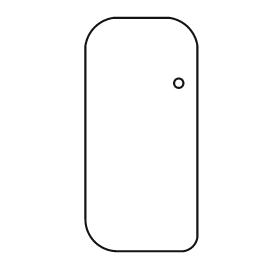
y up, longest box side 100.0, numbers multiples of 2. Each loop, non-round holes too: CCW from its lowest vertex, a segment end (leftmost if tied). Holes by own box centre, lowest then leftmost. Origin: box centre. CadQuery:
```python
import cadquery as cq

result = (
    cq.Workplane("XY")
    .moveTo(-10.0, -50.0)
    .lineTo(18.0, -50.0)
    .threePointArc((22.0, -48.0), (24.0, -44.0))
    .lineTo(24.0, 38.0)
    .threePointArc((20.0, 46.0), (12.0, 50.0))
    .lineTo(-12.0, 50.0)
    .threePointArc((-20.0, 46.0), (-24.0, 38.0))
    .lineTo(-24.0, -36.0)
    .threePointArc((-20.0, -46.0), (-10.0, -50.0))
    .close()
    .moveTo(16.0, 22.0)
    .circle(2.0)
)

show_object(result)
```